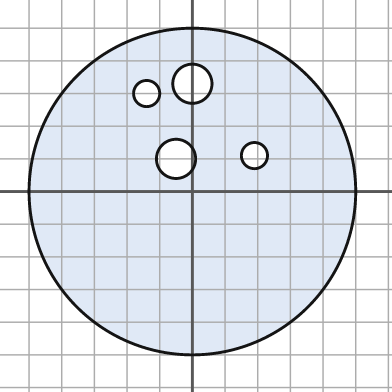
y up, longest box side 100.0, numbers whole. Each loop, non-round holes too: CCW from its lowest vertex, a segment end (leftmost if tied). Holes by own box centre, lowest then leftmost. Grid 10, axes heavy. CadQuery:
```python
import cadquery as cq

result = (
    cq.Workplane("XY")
    .moveTo(0.0, 0.0)
    .circle(50.0)
    .moveTo(-5.0, 10.0)
    .circle(6.0)
    .moveTo(19.0, 11.0)
    .circle(4.0)
    .moveTo(-14.0, 30.0)
    .circle(4.0)
    .moveTo(0.0, 33.0)
    .circle(6.0)
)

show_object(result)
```